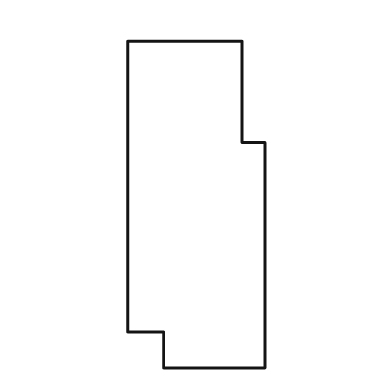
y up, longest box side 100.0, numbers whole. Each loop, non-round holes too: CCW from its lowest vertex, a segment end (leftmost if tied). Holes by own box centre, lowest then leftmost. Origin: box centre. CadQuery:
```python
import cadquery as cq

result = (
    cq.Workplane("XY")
    .moveTo(-10.0, -50.0)
    .lineTo(21.0, -50.0)
    .lineTo(21.0, 19.0)
    .lineTo(14.0, 19.0)
    .lineTo(14.0, 50.0)
    .lineTo(-21.0, 50.0)
    .lineTo(-21.0, -39.0)
    .lineTo(-10.0, -39.0)
    .close()
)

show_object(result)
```